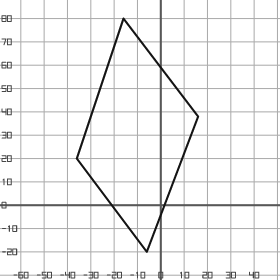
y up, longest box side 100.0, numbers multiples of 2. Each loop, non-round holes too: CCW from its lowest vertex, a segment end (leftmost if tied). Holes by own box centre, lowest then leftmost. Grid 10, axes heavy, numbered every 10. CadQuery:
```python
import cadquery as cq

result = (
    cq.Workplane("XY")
    .moveTo(-6.0, -20.0)
    .lineTo(16.0, 38.0)
    .lineTo(-16.0, 80.0)
    .lineTo(-36.0, 20.0)
    .close()
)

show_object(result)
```